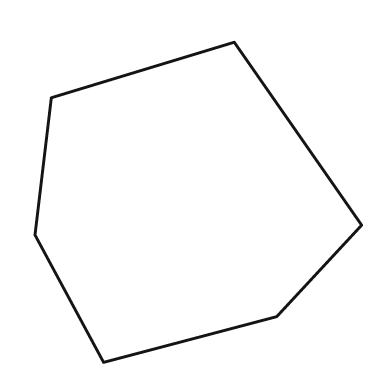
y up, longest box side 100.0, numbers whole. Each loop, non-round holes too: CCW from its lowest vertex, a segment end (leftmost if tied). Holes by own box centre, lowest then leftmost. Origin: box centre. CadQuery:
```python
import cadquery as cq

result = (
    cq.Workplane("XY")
    .moveTo(-29.0, -49.0)
    .lineTo(24.0, -35.0)
    .lineTo(50.0, -7.0)
    .lineTo(11.0, 49.0)
    .lineTo(-45.0, 32.0)
    .lineTo(-50.0, -10.0)
    .close()
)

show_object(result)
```